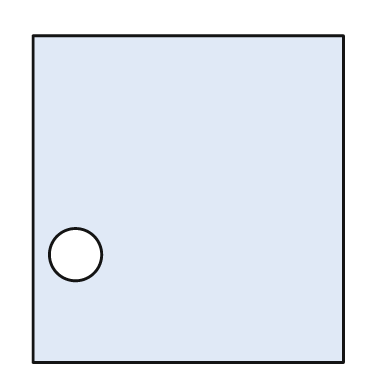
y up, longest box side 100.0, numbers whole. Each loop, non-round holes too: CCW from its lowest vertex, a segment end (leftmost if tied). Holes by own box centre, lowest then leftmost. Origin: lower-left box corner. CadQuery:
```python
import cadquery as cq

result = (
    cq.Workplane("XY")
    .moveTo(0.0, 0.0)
    .lineTo(95.0, 0.0)
    .lineTo(95.0, 100.0)
    .lineTo(0.0, 100.0)
    .close()
    .moveTo(13.0, 33.0)
    .circle(8.0)
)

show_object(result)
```